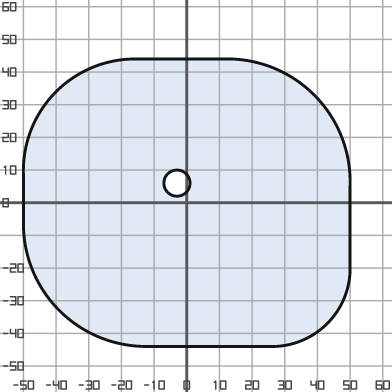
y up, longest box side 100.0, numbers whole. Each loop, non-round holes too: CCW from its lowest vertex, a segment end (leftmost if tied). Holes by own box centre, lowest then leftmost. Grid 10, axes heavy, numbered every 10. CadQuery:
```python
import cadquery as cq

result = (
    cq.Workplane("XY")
    .moveTo(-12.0, -44.0)
    .lineTo(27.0, -44.0)
    .threePointArc((43.0, -37.0), (50.0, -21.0))
    .lineTo(50.0, 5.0)
    .threePointArc((39.0, 33.0), (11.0, 44.0))
    .lineTo(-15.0, 44.0)
    .threePointArc((-40.0, 34.0), (-50.0, 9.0))
    .lineTo(-50.0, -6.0)
    .threePointArc((-39.0, -33.0), (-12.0, -44.0))
    .close()
    .moveTo(-3.0, 6.0)
    .circle(4.0)
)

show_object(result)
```